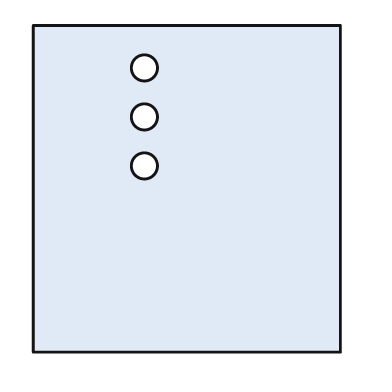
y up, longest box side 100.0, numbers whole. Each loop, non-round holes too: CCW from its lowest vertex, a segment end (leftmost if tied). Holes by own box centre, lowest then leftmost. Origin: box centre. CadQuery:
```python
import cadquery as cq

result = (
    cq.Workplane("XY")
    .moveTo(-47.0, -50.0)
    .lineTo(47.0, -50.0)
    .lineTo(47.0, 50.0)
    .lineTo(-47.0, 50.0)
    .close()
    .moveTo(-13.0, 7.0)
    .circle(4.0)
    .moveTo(-13.0, 22.0)
    .circle(4.0)
    .moveTo(-13.0, 37.0)
    .circle(4.0)
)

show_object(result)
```